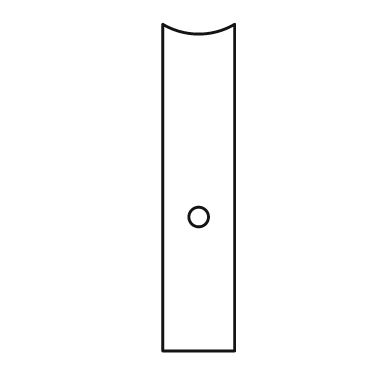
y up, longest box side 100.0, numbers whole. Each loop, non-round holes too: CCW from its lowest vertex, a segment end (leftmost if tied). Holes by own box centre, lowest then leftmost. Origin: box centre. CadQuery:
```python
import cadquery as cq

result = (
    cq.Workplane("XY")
    .moveTo(-11.0, -50.0)
    .lineTo(11.0, -50.0)
    .lineTo(11.0, 50.0)
    .threePointArc((0.0, 47.0), (-11.0, 50.0))
    .close()
    .moveTo(0.0, -9.0)
    .circle(3.0)
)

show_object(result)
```